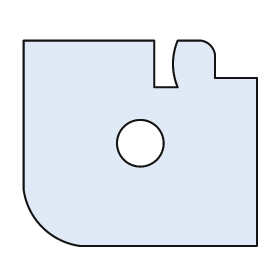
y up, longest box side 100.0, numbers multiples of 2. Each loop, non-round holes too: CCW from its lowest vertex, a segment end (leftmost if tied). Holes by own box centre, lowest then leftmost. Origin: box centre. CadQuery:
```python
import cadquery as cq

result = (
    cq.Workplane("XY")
    .moveTo(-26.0, -44.0)
    .lineTo(50.0, -44.0)
    .lineTo(50.0, 28.0)
    .lineTo(32.0, 28.0)
    .lineTo(32.0, 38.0)
    .threePointArc((30.0, 42.0), (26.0, 44.0))
    .lineTo(16.0, 44.0)
    .threePointArc((14.0, 34.0), (16.0, 24.0))
    .lineTo(6.0, 24.0)
    .lineTo(6.0, 44.0)
    .lineTo(-50.0, 44.0)
    .lineTo(-50.0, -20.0)
    .threePointArc((-42.0, -36.0), (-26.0, -44.0))
    .close()
    .moveTo(0.0, 0.0)
    .circle(10.0)
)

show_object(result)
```